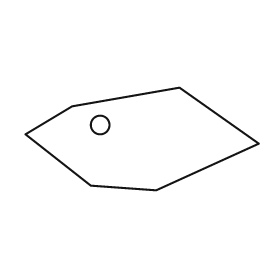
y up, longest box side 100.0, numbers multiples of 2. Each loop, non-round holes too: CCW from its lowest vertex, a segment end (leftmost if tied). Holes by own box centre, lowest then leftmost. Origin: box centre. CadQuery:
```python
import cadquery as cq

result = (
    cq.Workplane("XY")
    .moveTo(6.0, -22.0)
    .lineTo(50.0, -2.0)
    .lineTo(16.0, 22.0)
    .lineTo(-30.0, 14.0)
    .lineTo(-50.0, 2.0)
    .lineTo(-22.0, -20.0)
    .close()
    .moveTo(-18.0, 6.0)
    .circle(4.0)
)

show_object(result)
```